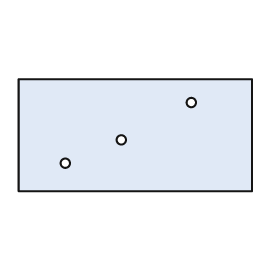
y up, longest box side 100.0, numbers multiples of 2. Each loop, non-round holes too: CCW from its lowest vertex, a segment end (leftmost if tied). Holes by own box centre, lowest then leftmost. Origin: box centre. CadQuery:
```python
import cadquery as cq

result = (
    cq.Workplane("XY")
    .moveTo(-50.0, -24.0)
    .lineTo(50.0, -24.0)
    .lineTo(50.0, 24.0)
    .lineTo(-50.0, 24.0)
    .close()
    .moveTo(-30.0, -12.0)
    .circle(2.0)
    .moveTo(-6.0, -2.0)
    .circle(2.0)
    .moveTo(24.0, 14.0)
    .circle(2.0)
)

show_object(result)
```